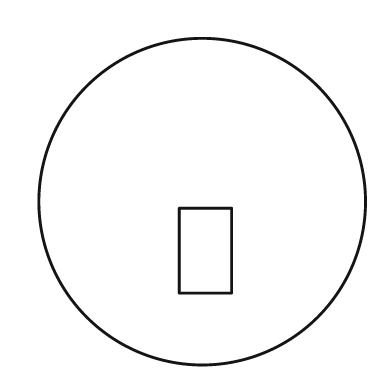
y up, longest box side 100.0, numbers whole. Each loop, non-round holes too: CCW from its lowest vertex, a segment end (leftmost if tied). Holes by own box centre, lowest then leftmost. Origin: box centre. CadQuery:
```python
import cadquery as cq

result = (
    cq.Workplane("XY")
    .moveTo(0.0, 0.0)
    .circle(50.0)
    .moveTo(-7.0, -28.0)
    .lineTo(9.0, -28.0)
    .lineTo(9.0, -2.0)
    .lineTo(-7.0, -2.0)
    .close()
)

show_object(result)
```